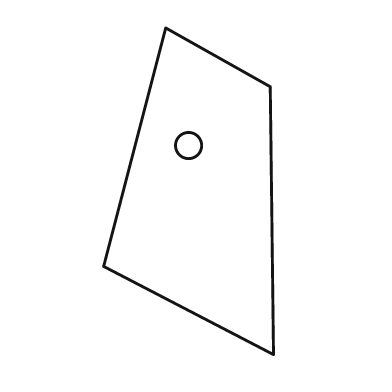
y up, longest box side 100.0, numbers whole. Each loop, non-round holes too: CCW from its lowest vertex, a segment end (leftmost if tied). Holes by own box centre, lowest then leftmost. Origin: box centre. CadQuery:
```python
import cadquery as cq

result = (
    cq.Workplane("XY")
    .moveTo(26.0, -50.0)
    .lineTo(25.0, 32.0)
    .lineTo(-7.0, 50.0)
    .lineTo(-26.0, -23.0)
    .close()
    .moveTo(0.0, 14.0)
    .circle(4.0)
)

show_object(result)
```